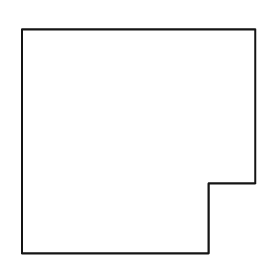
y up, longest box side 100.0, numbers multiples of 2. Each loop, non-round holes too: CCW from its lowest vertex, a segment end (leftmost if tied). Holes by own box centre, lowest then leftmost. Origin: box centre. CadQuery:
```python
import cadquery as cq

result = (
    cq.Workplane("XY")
    .moveTo(-50.0, -48.0)
    .lineTo(30.0, -48.0)
    .lineTo(30.0, -18.0)
    .lineTo(50.0, -18.0)
    .lineTo(50.0, 48.0)
    .lineTo(-50.0, 48.0)
    .close()
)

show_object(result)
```